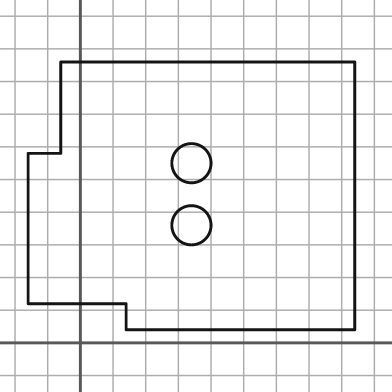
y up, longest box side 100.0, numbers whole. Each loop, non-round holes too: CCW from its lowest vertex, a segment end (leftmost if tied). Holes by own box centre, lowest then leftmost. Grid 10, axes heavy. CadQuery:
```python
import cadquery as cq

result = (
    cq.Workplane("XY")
    .moveTo(14.0, 4.0)
    .lineTo(84.0, 4.0)
    .lineTo(84.0, 86.0)
    .lineTo(-6.0, 86.0)
    .lineTo(-6.0, 58.0)
    .lineTo(-16.0, 58.0)
    .lineTo(-16.0, 12.0)
    .lineTo(14.0, 12.0)
    .close()
    .moveTo(34.0, 36.0)
    .circle(6.0)
    .moveTo(34.0, 55.0)
    .circle(6.0)
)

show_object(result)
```